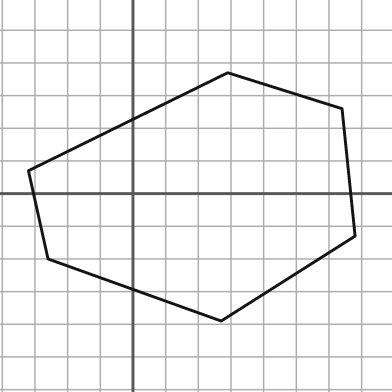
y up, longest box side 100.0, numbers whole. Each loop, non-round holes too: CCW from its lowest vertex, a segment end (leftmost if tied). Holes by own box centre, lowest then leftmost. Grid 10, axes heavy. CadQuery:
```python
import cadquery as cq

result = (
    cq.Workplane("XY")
    .moveTo(27.0, -39.0)
    .lineTo(68.0, -13.0)
    .lineTo(64.0, 26.0)
    .lineTo(29.0, 37.0)
    .lineTo(-32.0, 7.0)
    .lineTo(-26.0, -20.0)
    .close()
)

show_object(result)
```